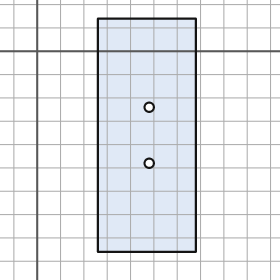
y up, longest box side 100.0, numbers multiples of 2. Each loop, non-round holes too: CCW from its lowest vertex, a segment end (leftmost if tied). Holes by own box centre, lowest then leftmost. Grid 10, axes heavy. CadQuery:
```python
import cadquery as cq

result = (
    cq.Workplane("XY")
    .moveTo(26.0, -86.0)
    .lineTo(68.0, -86.0)
    .lineTo(68.0, 14.0)
    .lineTo(26.0, 14.0)
    .close()
    .moveTo(48.0, -48.0)
    .circle(2.0)
    .moveTo(48.0, -24.0)
    .circle(2.0)
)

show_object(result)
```